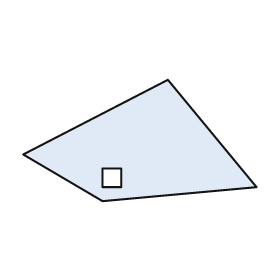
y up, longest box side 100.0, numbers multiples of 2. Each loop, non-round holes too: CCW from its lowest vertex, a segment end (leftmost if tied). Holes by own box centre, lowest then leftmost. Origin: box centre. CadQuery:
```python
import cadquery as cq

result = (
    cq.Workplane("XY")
    .moveTo(-16.0, -26.0)
    .lineTo(50.0, -20.0)
    .lineTo(12.0, 26.0)
    .lineTo(-50.0, -6.0)
    .close()
    .moveTo(-16.0, -20.0)
    .lineTo(-8.0, -20.0)
    .lineTo(-8.0, -12.0)
    .lineTo(-16.0, -12.0)
    .close()
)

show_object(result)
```